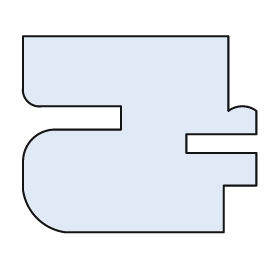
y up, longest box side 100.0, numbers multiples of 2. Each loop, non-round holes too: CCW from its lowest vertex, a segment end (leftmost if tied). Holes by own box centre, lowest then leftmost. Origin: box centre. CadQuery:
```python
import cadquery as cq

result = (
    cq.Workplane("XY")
    .moveTo(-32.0, -42.0)
    .lineTo(36.0, -42.0)
    .lineTo(36.0, -22.0)
    .lineTo(50.0, -22.0)
    .lineTo(50.0, -8.0)
    .lineTo(20.0, -8.0)
    .lineTo(20.0, 0.0)
    .lineTo(50.0, 0.0)
    .lineTo(50.0, 10.0)
    .threePointArc((44.0, 12.0), (38.0, 10.0))
    .lineTo(38.0, 42.0)
    .lineTo(-50.0, 42.0)
    .lineTo(-50.0, 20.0)
    .threePointArc((-48.0, 14.0), (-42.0, 12.0))
    .lineTo(-8.0, 12.0)
    .lineTo(-8.0, 2.0)
    .lineTo(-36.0, 2.0)
    .threePointArc((-46.0, -2.0), (-50.0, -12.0))
    .lineTo(-50.0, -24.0)
    .threePointArc((-44.0, -36.0), (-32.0, -42.0))
    .close()
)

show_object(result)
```